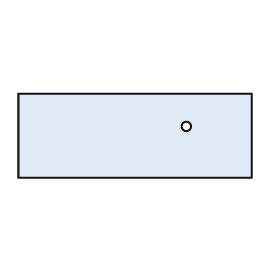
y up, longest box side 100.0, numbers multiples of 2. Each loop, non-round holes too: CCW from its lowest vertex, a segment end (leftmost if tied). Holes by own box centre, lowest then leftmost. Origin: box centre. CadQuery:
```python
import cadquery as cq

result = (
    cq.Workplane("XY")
    .moveTo(-50.0, -18.0)
    .lineTo(50.0, -18.0)
    .lineTo(50.0, 18.0)
    .lineTo(-50.0, 18.0)
    .close()
    .moveTo(22.0, 4.0)
    .circle(2.0)
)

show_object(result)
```